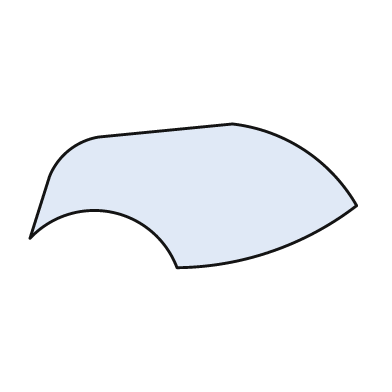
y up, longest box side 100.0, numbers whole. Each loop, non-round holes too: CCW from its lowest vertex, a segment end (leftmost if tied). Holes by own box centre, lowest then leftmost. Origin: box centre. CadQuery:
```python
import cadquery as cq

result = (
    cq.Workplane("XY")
    .moveTo(-5.0, -22.0)
    .threePointArc((24.0, -17.0), (50.0, -3.0))
    .threePointArc((34.0, 14.0), (12.0, 22.0))
    .lineTo(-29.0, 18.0)
    .threePointArc((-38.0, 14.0), (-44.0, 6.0))
    .lineTo(-50.0, -13.0)
    .threePointArc((-25.0, -5.0), (-5.0, -22.0))
    .close()
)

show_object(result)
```